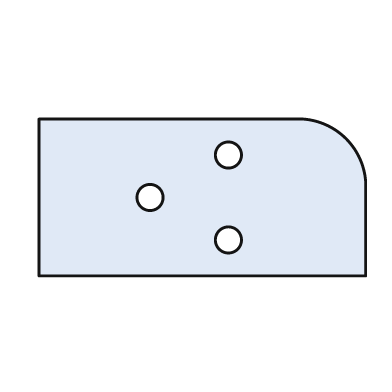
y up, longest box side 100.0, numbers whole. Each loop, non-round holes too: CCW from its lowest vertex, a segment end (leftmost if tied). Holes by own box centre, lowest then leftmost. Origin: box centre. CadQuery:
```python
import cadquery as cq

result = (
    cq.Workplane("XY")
    .moveTo(-50.0, -24.0)
    .lineTo(50.0, -24.0)
    .lineTo(50.0, 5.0)
    .threePointArc((44.0, 18.0), (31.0, 24.0))
    .lineTo(-50.0, 24.0)
    .close()
    .moveTo(8.0, -13.0)
    .circle(4.0)
    .moveTo(-16.0, 0.0)
    .circle(4.0)
    .moveTo(8.0, 13.0)
    .circle(4.0)
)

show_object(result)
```